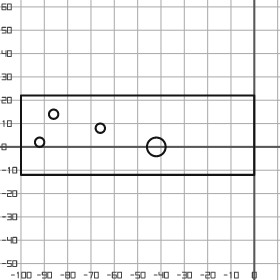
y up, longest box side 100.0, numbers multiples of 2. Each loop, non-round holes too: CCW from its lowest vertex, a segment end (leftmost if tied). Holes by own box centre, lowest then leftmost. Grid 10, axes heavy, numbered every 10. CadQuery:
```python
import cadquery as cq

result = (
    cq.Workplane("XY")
    .moveTo(-100.0, -12.0)
    .lineTo(0.0, -12.0)
    .lineTo(0.0, 22.0)
    .lineTo(-100.0, 22.0)
    .close()
    .moveTo(-42.0, 0.0)
    .circle(4.0)
    .moveTo(-92.0, 2.0)
    .circle(2.0)
    .moveTo(-66.0, 8.0)
    .circle(2.0)
    .moveTo(-86.0, 14.0)
    .circle(2.0)
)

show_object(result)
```